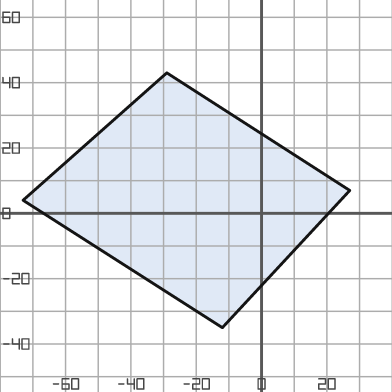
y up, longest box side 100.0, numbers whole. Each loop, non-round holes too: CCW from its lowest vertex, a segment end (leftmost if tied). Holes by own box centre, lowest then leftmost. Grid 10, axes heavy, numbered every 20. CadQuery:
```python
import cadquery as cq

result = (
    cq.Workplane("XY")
    .moveTo(-12.0, -35.0)
    .lineTo(27.0, 7.0)
    .lineTo(-29.0, 43.0)
    .lineTo(-73.0, 4.0)
    .close()
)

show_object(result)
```